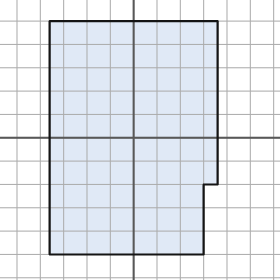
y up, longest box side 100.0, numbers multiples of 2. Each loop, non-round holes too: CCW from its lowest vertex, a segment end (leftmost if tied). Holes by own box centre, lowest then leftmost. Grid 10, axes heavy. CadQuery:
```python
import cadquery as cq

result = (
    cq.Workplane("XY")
    .moveTo(-36.0, -50.0)
    .lineTo(30.0, -50.0)
    .lineTo(30.0, -20.0)
    .lineTo(36.0, -20.0)
    .lineTo(36.0, 50.0)
    .lineTo(-36.0, 50.0)
    .close()
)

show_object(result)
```